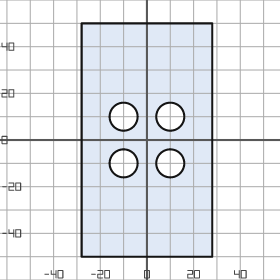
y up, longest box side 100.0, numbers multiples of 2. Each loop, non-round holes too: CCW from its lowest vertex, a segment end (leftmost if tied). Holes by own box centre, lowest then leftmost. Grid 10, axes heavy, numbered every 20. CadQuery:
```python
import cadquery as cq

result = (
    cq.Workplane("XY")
    .moveTo(-28.0, -50.0)
    .lineTo(28.0, -50.0)
    .lineTo(28.0, 50.0)
    .lineTo(-28.0, 50.0)
    .close()
    .moveTo(-10.0, -10.0)
    .circle(6.0)
    .moveTo(10.0, -10.0)
    .circle(6.0)
    .moveTo(-10.0, 10.0)
    .circle(6.0)
    .moveTo(10.0, 10.0)
    .circle(6.0)
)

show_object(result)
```